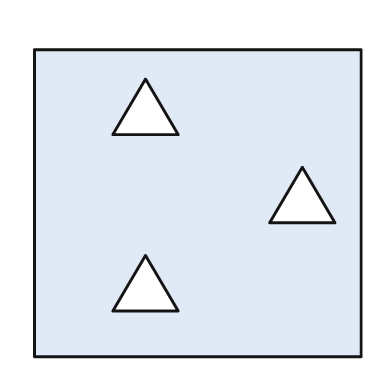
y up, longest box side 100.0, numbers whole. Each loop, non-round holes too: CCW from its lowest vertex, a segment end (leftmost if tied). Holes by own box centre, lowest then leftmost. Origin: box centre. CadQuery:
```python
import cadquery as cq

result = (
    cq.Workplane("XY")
    .moveTo(-50.0, -47.0)
    .lineTo(50.0, -47.0)
    .lineTo(50.0, 47.0)
    .lineTo(-50.0, 47.0)
    .close()
    .moveTo(-26.0, -33.0)
    .lineTo(-6.0, -33.0)
    .lineTo(-16.0, -16.0)
    .close()
    .moveTo(22.0, -6.0)
    .lineTo(42.0, -6.0)
    .lineTo(32.0, 11.0)
    .close()
    .moveTo(-26.0, 21.0)
    .lineTo(-6.0, 21.0)
    .lineTo(-16.0, 38.0)
    .close()
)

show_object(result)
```